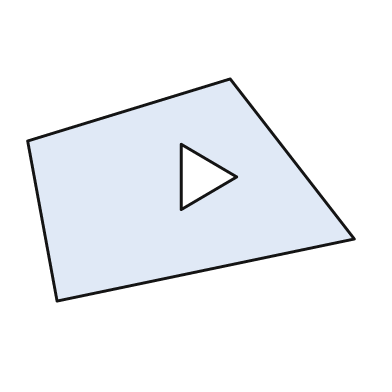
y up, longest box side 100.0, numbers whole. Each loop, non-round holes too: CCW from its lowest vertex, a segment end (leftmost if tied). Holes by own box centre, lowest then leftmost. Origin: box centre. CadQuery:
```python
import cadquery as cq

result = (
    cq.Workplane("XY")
    .moveTo(-41.0, -34.0)
    .lineTo(50.0, -15.0)
    .lineTo(12.0, 34.0)
    .lineTo(-50.0, 15.0)
    .close()
    .moveTo(-3.0, -6.0)
    .lineTo(14.0, 4.0)
    .lineTo(-3.0, 14.0)
    .close()
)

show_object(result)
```